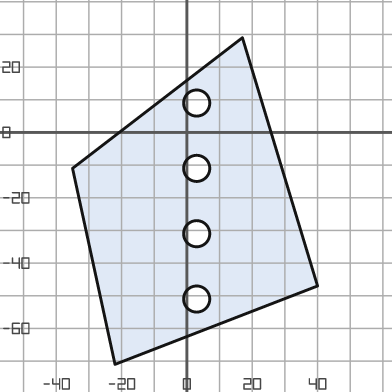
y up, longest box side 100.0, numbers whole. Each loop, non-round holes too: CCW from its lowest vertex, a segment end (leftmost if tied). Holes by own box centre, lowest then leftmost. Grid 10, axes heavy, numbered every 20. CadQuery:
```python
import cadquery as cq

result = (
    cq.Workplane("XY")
    .moveTo(-22.0, -71.0)
    .lineTo(40.0, -47.0)
    .lineTo(17.0, 29.0)
    .lineTo(-35.0, -11.0)
    .close()
    .moveTo(3.0, -51.0)
    .circle(4.0)
    .moveTo(3.0, -31.0)
    .circle(4.0)
    .moveTo(3.0, -11.0)
    .circle(4.0)
    .moveTo(3.0, 9.0)
    .circle(4.0)
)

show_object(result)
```